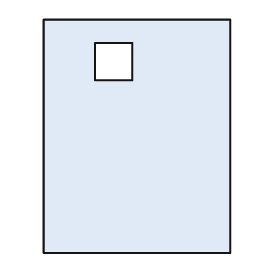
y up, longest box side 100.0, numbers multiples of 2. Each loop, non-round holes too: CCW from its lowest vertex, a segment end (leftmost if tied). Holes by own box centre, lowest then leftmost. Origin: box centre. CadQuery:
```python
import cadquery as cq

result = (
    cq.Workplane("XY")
    .moveTo(-40.0, -50.0)
    .lineTo(40.0, -50.0)
    .lineTo(40.0, 50.0)
    .lineTo(-40.0, 50.0)
    .close()
    .moveTo(-18.0, 24.0)
    .lineTo(-2.0, 24.0)
    .lineTo(-2.0, 40.0)
    .lineTo(-18.0, 40.0)
    .close()
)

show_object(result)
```